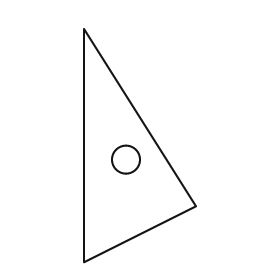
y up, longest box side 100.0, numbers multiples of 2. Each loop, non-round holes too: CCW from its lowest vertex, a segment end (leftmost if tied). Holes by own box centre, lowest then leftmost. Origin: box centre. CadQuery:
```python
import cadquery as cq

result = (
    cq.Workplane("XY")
    .moveTo(-24.0, -50.0)
    .lineTo(24.0, -26.0)
    .lineTo(-24.0, 50.0)
    .close()
    .moveTo(-6.0, -6.0)
    .circle(6.0)
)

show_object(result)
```